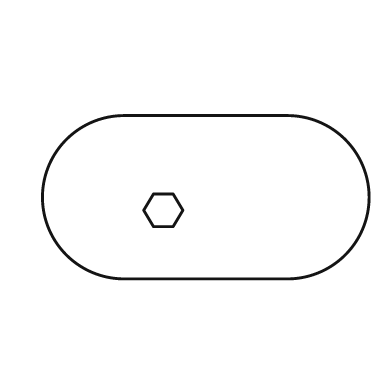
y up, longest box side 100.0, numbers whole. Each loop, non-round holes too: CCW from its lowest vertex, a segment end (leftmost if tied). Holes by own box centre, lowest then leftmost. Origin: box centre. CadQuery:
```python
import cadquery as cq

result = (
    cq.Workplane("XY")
    .moveTo(-25.0, -25.0)
    .lineTo(25.0, -25.0)
    .threePointArc((50.0, 0.0), (25.0, 25.0))
    .lineTo(-25.0, 25.0)
    .threePointArc((-50.0, 0.0), (-25.0, -25.0))
    .close()
    .moveTo(-16.0, -9.0)
    .lineTo(-10.0, -9.0)
    .lineTo(-7.0, -4.0)
    .lineTo(-10.0, 1.0)
    .lineTo(-16.0, 1.0)
    .lineTo(-19.0, -4.0)
    .close()
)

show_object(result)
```